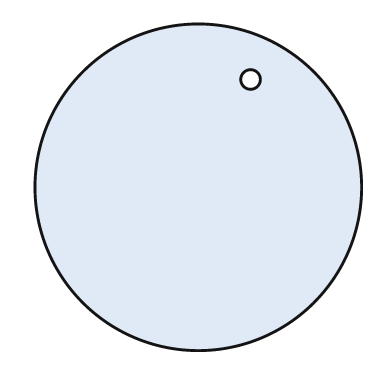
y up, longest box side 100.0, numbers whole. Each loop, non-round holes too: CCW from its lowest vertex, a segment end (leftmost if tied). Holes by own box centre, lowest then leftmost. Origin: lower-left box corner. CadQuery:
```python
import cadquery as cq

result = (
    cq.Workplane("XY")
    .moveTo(50.0, 50.0)
    .circle(50.0)
    .moveTo(66.0, 83.0)
    .circle(3.0)
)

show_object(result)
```